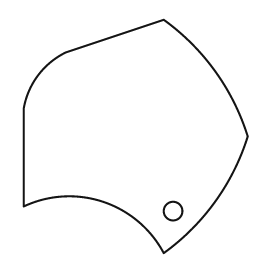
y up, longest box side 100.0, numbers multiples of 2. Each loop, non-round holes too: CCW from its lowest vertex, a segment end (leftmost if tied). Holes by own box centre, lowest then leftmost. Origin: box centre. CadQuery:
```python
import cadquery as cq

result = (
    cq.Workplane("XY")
    .moveTo(12.0, -50.0)
    .threePointArc((34.0, -28.0), (48.0, 0.0))
    .threePointArc((34.0, 28.0), (12.0, 50.0))
    .lineTo(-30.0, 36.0)
    .threePointArc((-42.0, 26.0), (-48.0, 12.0))
    .lineTo(-48.0, -30.0)
    .threePointArc((-14.0, -28.0), (12.0, -50.0))
    .close()
    .moveTo(16.0, -32.0)
    .circle(4.0)
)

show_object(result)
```